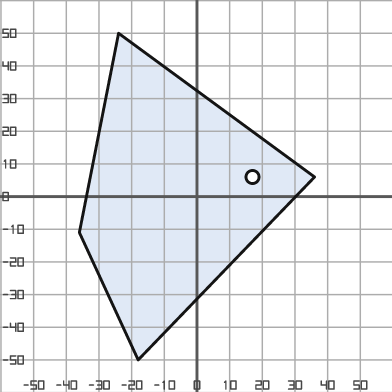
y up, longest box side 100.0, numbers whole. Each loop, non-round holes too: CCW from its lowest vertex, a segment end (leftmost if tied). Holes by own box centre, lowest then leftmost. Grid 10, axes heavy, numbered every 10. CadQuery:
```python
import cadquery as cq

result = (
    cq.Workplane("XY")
    .moveTo(-18.0, -50.0)
    .lineTo(36.0, 6.0)
    .lineTo(-24.0, 50.0)
    .lineTo(-36.0, -11.0)
    .close()
    .moveTo(17.0, 6.0)
    .circle(2.0)
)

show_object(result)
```